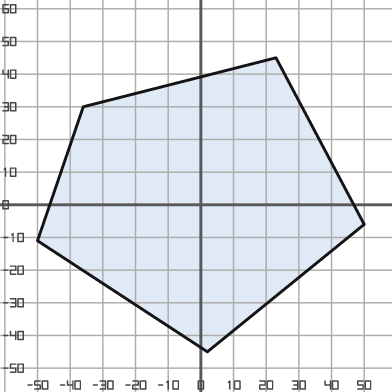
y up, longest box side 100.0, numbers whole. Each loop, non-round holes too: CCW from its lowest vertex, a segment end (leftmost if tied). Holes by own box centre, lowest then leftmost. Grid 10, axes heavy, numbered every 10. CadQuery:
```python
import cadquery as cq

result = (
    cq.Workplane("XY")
    .moveTo(2.0, -45.0)
    .lineTo(50.0, -6.0)
    .lineTo(23.0, 45.0)
    .lineTo(-36.0, 30.0)
    .lineTo(-50.0, -11.0)
    .close()
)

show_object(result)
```